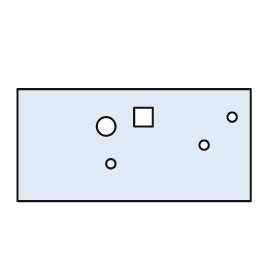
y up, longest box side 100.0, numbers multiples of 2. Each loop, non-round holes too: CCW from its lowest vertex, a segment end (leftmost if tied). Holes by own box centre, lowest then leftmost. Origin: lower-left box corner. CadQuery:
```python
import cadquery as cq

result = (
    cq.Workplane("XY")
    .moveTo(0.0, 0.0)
    .lineTo(100.0, 0.0)
    .lineTo(100.0, 48.0)
    .lineTo(0.0, 48.0)
    .close()
    .moveTo(40.0, 16.0)
    .circle(2.0)
    .moveTo(80.0, 24.0)
    .circle(2.0)
    .moveTo(38.0, 32.0)
    .circle(4.0)
    .moveTo(50.0, 32.0)
    .lineTo(58.0, 32.0)
    .lineTo(58.0, 40.0)
    .lineTo(50.0, 40.0)
    .close()
    .moveTo(92.0, 36.0)
    .circle(2.0)
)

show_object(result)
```